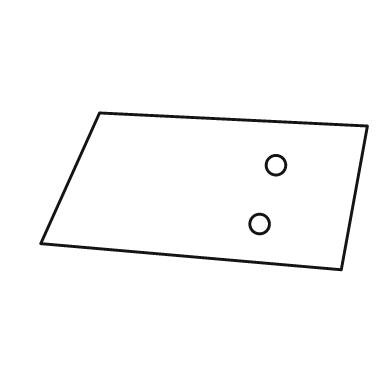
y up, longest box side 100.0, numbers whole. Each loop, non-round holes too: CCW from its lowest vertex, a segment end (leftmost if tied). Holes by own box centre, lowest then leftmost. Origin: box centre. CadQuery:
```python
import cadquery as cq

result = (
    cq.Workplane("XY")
    .moveTo(42.0, -24.0)
    .lineTo(50.0, 20.0)
    .lineTo(-32.0, 24.0)
    .lineTo(-50.0, -16.0)
    .close()
    .moveTo(17.0, -10.0)
    .circle(3.0)
    .moveTo(22.0, 8.0)
    .circle(3.0)
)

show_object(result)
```